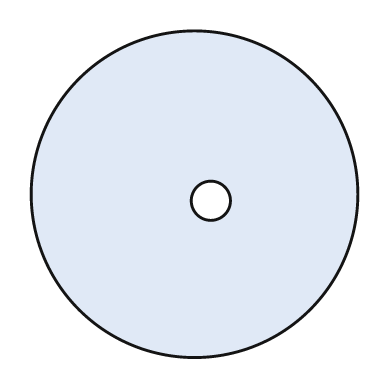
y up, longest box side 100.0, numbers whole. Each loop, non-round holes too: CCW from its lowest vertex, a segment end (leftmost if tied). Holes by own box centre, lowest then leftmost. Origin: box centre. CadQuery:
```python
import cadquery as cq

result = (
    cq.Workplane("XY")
    .moveTo(0.0, 0.0)
    .circle(50.0)
    .moveTo(5.0, -2.0)
    .circle(6.0)
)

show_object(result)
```